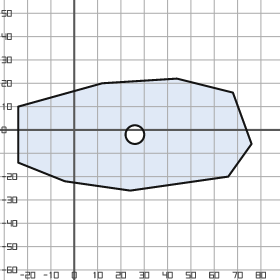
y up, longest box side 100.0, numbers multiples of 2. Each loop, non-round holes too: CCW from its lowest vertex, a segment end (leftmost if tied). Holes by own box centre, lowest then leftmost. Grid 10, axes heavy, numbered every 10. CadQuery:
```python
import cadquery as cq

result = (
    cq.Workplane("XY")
    .moveTo(24.0, -26.0)
    .lineTo(66.0, -20.0)
    .lineTo(76.0, -6.0)
    .lineTo(68.0, 16.0)
    .lineTo(44.0, 22.0)
    .lineTo(12.0, 20.0)
    .lineTo(-24.0, 10.0)
    .lineTo(-24.0, -14.0)
    .lineTo(-4.0, -22.0)
    .close()
    .moveTo(26.0, -2.0)
    .circle(4.0)
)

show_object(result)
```